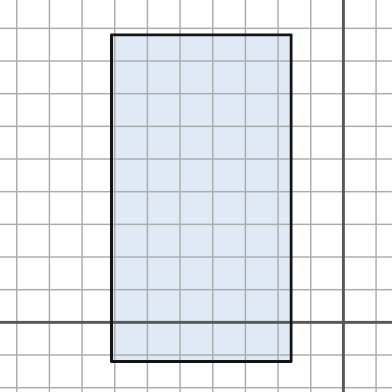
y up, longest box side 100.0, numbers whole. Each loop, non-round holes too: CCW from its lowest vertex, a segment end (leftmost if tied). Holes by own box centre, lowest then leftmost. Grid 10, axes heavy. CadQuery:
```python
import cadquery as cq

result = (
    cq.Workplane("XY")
    .moveTo(-71.0, -12.0)
    .lineTo(-16.0, -12.0)
    .lineTo(-16.0, 88.0)
    .lineTo(-71.0, 88.0)
    .close()
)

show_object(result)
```